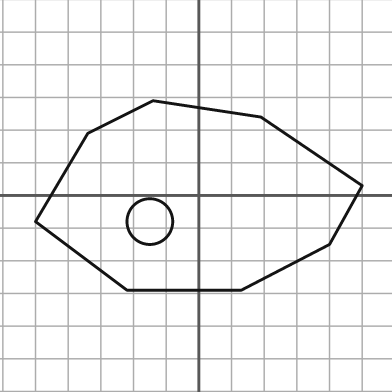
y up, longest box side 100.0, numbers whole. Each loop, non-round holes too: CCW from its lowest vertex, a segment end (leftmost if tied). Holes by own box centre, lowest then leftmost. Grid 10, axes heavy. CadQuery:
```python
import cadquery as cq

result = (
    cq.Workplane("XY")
    .moveTo(-22.0, -29.0)
    .lineTo(13.0, -29.0)
    .lineTo(40.0, -15.0)
    .lineTo(50.0, 3.0)
    .lineTo(19.0, 24.0)
    .lineTo(-14.0, 29.0)
    .lineTo(-34.0, 19.0)
    .lineTo(-50.0, -8.0)
    .close()
    .moveTo(-15.0, -8.0)
    .circle(7.0)
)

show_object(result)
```